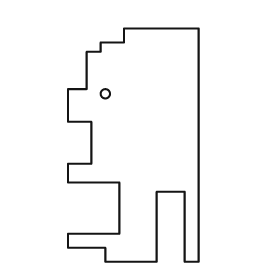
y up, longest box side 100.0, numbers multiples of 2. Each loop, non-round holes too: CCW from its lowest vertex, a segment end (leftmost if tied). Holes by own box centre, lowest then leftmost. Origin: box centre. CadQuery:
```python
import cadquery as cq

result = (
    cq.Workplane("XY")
    .moveTo(-12.0, -50.0)
    .lineTo(10.0, -50.0)
    .lineTo(10.0, -20.0)
    .lineTo(22.0, -20.0)
    .lineTo(22.0, -50.0)
    .lineTo(28.0, -50.0)
    .lineTo(28.0, 50.0)
    .lineTo(-4.0, 50.0)
    .lineTo(-4.0, 44.0)
    .lineTo(-14.0, 44.0)
    .lineTo(-14.0, 40.0)
    .lineTo(-20.0, 40.0)
    .lineTo(-20.0, 24.0)
    .lineTo(-28.0, 24.0)
    .lineTo(-28.0, 10.0)
    .lineTo(-18.0, 10.0)
    .lineTo(-18.0, -8.0)
    .lineTo(-28.0, -8.0)
    .lineTo(-28.0, -16.0)
    .lineTo(-6.0, -16.0)
    .lineTo(-6.0, -38.0)
    .lineTo(-28.0, -38.0)
    .lineTo(-28.0, -44.0)
    .lineTo(-12.0, -44.0)
    .close()
    .moveTo(-12.0, 22.0)
    .circle(2.0)
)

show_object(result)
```